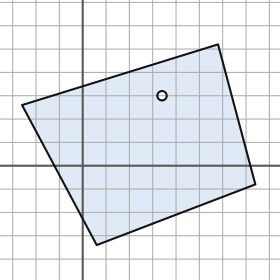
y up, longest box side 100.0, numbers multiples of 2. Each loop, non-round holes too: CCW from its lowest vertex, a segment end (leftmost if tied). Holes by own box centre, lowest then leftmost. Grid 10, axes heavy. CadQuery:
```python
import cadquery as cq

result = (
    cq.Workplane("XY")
    .moveTo(6.0, -34.0)
    .lineTo(74.0, -8.0)
    .lineTo(58.0, 52.0)
    .lineTo(-26.0, 26.0)
    .close()
    .moveTo(34.0, 30.0)
    .circle(2.0)
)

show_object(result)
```